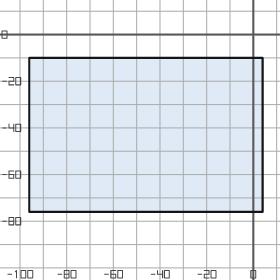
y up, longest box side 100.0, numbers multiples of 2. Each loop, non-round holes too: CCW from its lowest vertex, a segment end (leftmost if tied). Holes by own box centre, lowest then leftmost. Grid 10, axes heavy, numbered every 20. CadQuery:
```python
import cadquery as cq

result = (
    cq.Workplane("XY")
    .moveTo(-96.0, -76.0)
    .lineTo(4.0, -76.0)
    .lineTo(4.0, -10.0)
    .lineTo(-96.0, -10.0)
    .close()
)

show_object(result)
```